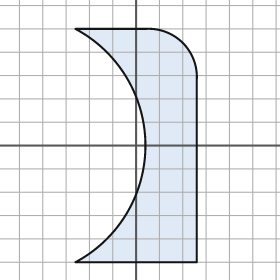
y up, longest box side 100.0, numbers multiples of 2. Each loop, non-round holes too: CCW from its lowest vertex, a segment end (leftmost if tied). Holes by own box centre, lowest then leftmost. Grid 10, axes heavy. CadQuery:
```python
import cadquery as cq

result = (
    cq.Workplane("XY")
    .moveTo(-26.0, -50.0)
    .lineTo(26.0, -50.0)
    .lineTo(26.0, 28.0)
    .threePointArc((20.0, 44.0), (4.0, 50.0))
    .lineTo(-26.0, 50.0)
    .threePointArc((4.0, 0.0), (-26.0, -50.0))
    .close()
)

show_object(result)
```